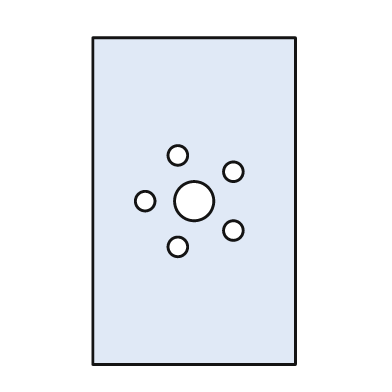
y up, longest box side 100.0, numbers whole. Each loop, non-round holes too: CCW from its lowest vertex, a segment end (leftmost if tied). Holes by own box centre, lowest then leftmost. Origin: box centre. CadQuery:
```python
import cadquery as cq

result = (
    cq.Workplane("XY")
    .moveTo(-31.0, -50.0)
    .lineTo(31.0, -50.0)
    .lineTo(31.0, 50.0)
    .lineTo(-31.0, 50.0)
    .close()
    .moveTo(-5.0, -14.0)
    .circle(3.0)
    .moveTo(12.0, -9.0)
    .circle(3.0)
    .moveTo(-15.0, 0.0)
    .circle(3.0)
    .moveTo(0.0, 0.0)
    .circle(6.0)
    .moveTo(12.0, 9.0)
    .circle(3.0)
    .moveTo(-5.0, 14.0)
    .circle(3.0)
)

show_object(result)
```